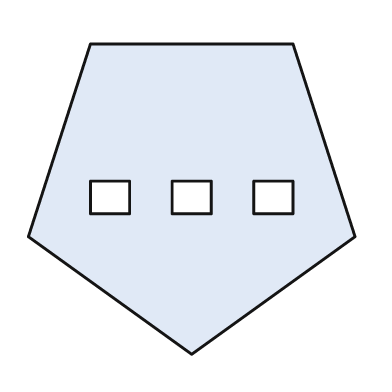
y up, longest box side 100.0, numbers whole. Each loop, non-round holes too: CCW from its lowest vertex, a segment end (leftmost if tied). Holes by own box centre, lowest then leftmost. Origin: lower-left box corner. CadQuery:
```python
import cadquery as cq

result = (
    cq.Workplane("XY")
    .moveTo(50.0, 0.0)
    .lineTo(100.0, 36.0)
    .lineTo(81.0, 95.0)
    .lineTo(19.0, 95.0)
    .lineTo(0.0, 36.0)
    .close()
    .moveTo(19.0, 43.0)
    .lineTo(31.0, 43.0)
    .lineTo(31.0, 53.0)
    .lineTo(19.0, 53.0)
    .close()
    .moveTo(44.0, 43.0)
    .lineTo(56.0, 43.0)
    .lineTo(56.0, 53.0)
    .lineTo(44.0, 53.0)
    .close()
    .moveTo(69.0, 43.0)
    .lineTo(81.0, 43.0)
    .lineTo(81.0, 53.0)
    .lineTo(69.0, 53.0)
    .close()
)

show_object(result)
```